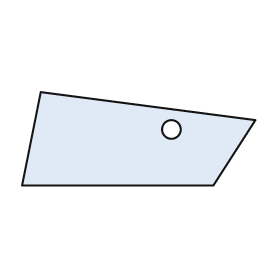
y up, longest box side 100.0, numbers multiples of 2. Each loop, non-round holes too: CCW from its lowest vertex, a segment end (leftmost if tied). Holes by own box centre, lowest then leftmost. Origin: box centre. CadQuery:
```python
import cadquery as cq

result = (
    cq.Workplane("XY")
    .moveTo(-50.0, -20.0)
    .lineTo(32.0, -20.0)
    .lineTo(50.0, 8.0)
    .lineTo(-42.0, 20.0)
    .close()
    .moveTo(14.0, 4.0)
    .circle(4.0)
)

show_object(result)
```